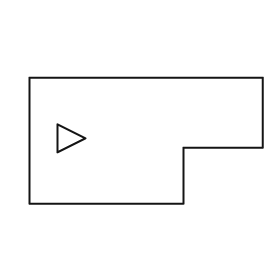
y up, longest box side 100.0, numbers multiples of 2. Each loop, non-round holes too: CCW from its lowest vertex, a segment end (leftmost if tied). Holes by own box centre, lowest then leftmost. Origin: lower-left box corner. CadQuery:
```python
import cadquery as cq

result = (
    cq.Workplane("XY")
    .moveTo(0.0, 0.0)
    .lineTo(66.0, 0.0)
    .lineTo(66.0, 24.0)
    .lineTo(100.0, 24.0)
    .lineTo(100.0, 54.0)
    .lineTo(0.0, 54.0)
    .close()
    .moveTo(12.0, 22.0)
    .lineTo(24.0, 28.0)
    .lineTo(12.0, 34.0)
    .close()
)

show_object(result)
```